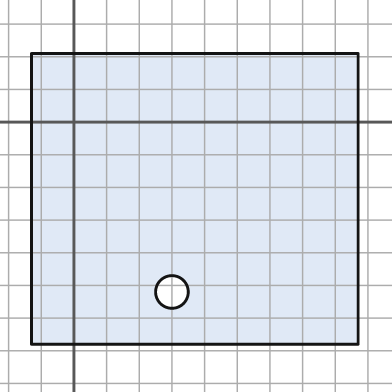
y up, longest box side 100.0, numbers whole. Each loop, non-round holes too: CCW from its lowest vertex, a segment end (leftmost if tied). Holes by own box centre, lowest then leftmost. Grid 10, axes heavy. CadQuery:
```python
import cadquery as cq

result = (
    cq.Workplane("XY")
    .moveTo(-13.0, -68.0)
    .lineTo(87.0, -68.0)
    .lineTo(87.0, 21.0)
    .lineTo(-13.0, 21.0)
    .close()
    .moveTo(30.0, -52.0)
    .circle(5.0)
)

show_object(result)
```